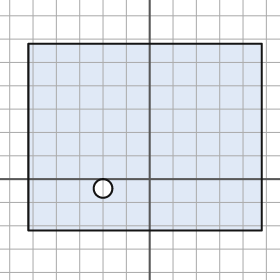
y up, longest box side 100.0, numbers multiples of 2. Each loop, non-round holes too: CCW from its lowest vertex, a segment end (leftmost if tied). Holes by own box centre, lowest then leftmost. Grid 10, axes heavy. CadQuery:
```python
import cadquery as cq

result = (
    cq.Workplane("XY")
    .moveTo(-52.0, -22.0)
    .lineTo(48.0, -22.0)
    .lineTo(48.0, 58.0)
    .lineTo(-52.0, 58.0)
    .close()
    .moveTo(-20.0, -4.0)
    .circle(4.0)
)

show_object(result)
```